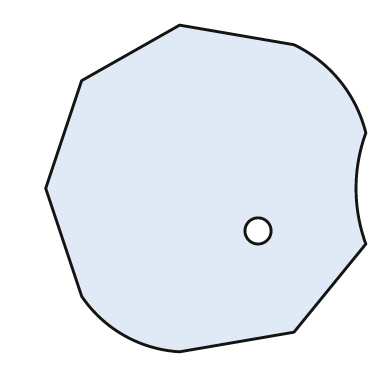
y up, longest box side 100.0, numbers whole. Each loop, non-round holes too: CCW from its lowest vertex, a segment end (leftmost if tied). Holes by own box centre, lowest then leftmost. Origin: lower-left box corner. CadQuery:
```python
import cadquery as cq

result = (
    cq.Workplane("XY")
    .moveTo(41.0, 0.0)
    .lineTo(76.0, 6.0)
    .lineTo(98.0, 33.0)
    .threePointArc((95.0, 50.0), (98.0, 67.0))
    .threePointArc((90.0, 83.0), (76.0, 94.0))
    .lineTo(41.0, 100.0)
    .lineTo(11.0, 83.0)
    .lineTo(0.0, 50.0)
    .lineTo(11.0, 17.0)
    .threePointArc((24.0, 5.0), (41.0, 0.0))
    .close()
    .moveTo(65.0, 37.0)
    .circle(4.0)
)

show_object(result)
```